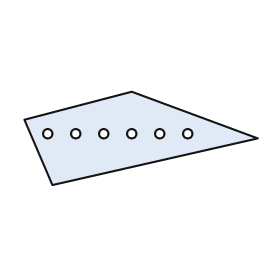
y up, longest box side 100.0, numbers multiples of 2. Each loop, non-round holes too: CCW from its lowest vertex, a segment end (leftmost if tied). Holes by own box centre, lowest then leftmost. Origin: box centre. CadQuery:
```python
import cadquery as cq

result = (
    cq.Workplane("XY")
    .moveTo(-38.0, -20.0)
    .lineTo(50.0, 0.0)
    .lineTo(-4.0, 20.0)
    .lineTo(-50.0, 8.0)
    .close()
    .moveTo(-40.0, 2.0)
    .circle(2.0)
    .moveTo(-28.0, 2.0)
    .circle(2.0)
    .moveTo(-16.0, 2.0)
    .circle(2.0)
    .moveTo(-4.0, 2.0)
    .circle(2.0)
    .moveTo(8.0, 2.0)
    .circle(2.0)
    .moveTo(20.0, 2.0)
    .circle(2.0)
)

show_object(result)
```